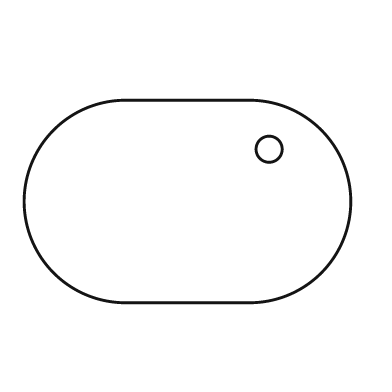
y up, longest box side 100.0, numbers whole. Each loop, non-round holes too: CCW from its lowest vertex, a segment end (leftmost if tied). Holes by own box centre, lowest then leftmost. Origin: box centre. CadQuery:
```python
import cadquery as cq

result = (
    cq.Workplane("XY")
    .moveTo(-19.0, -31.0)
    .lineTo(19.0, -31.0)
    .threePointArc((50.0, 0.0), (19.0, 31.0))
    .lineTo(-19.0, 31.0)
    .threePointArc((-50.0, 0.0), (-19.0, -31.0))
    .close()
    .moveTo(25.0, 16.0)
    .circle(4.0)
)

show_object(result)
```